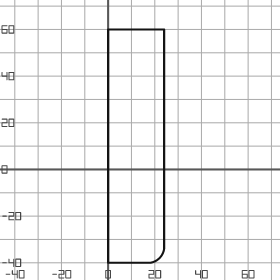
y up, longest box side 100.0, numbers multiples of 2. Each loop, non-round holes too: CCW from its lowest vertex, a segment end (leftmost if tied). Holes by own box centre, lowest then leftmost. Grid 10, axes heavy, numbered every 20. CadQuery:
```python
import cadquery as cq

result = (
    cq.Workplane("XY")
    .moveTo(0.0, -40.0)
    .lineTo(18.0, -40.0)
    .threePointArc((22.0, -38.0), (24.0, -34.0))
    .lineTo(24.0, 60.0)
    .lineTo(0.0, 60.0)
    .close()
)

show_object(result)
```